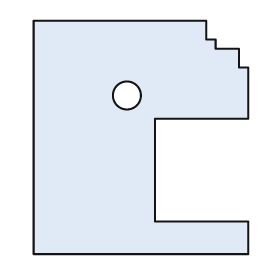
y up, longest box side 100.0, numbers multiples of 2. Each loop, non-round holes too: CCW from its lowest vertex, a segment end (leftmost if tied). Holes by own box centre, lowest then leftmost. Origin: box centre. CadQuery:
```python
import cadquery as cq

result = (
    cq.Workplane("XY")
    .moveTo(-46.0, -50.0)
    .lineTo(46.0, -50.0)
    .lineTo(46.0, -36.0)
    .lineTo(6.0, -36.0)
    .lineTo(6.0, 8.0)
    .lineTo(46.0, 8.0)
    .lineTo(46.0, 30.0)
    .lineTo(42.0, 30.0)
    .lineTo(42.0, 38.0)
    .lineTo(32.0, 38.0)
    .lineTo(32.0, 42.0)
    .lineTo(28.0, 42.0)
    .lineTo(28.0, 50.0)
    .lineTo(-46.0, 50.0)
    .close()
    .moveTo(-6.0, 18.0)
    .circle(6.0)
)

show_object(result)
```